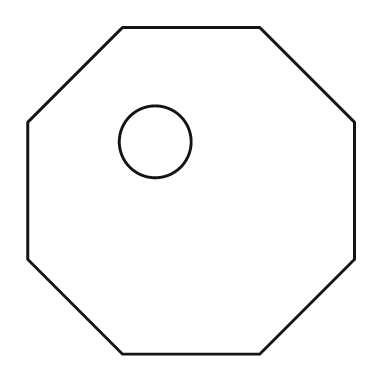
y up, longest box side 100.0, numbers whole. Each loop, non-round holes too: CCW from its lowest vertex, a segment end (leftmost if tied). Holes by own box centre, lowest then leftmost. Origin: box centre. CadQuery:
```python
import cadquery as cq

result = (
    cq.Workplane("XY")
    .moveTo(-21.0, -50.0)
    .lineTo(21.0, -50.0)
    .lineTo(50.0, -21.0)
    .lineTo(50.0, 21.0)
    .lineTo(21.0, 50.0)
    .lineTo(-21.0, 50.0)
    .lineTo(-50.0, 21.0)
    .lineTo(-50.0, -21.0)
    .close()
    .moveTo(-11.0, 15.0)
    .circle(11.0)
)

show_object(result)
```